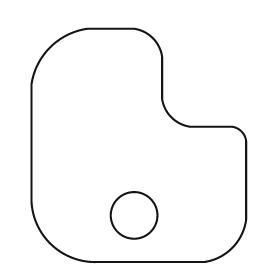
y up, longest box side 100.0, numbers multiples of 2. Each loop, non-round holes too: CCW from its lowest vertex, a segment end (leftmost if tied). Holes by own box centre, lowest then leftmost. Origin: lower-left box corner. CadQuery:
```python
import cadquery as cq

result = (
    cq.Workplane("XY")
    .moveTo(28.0, 0.0)
    .lineTo(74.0, 0.0)
    .threePointArc((86.0, 6.0), (92.0, 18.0))
    .lineTo(92.0, 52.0)
    .threePointArc((90.0, 56.0), (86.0, 58.0))
    .lineTo(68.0, 58.0)
    .threePointArc((60.0, 62.0), (56.0, 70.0))
    .lineTo(56.0, 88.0)
    .threePointArc((52.0, 96.0), (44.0, 100.0))
    .lineTo(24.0, 100.0)
    .threePointArc((8.0, 92.0), (0.0, 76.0))
    .lineTo(0.0, 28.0)
    .threePointArc((8.0, 8.0), (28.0, 0.0))
    .close()
    .moveTo(44.0, 20.0)
    .circle(10.0)
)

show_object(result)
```